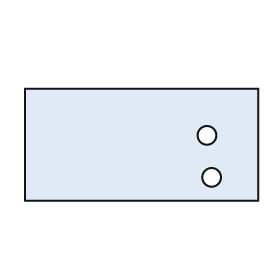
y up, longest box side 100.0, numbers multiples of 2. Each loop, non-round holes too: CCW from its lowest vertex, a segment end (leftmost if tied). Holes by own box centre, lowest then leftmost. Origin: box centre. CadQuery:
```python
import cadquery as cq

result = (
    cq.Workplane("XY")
    .moveTo(-50.0, -24.0)
    .lineTo(50.0, -24.0)
    .lineTo(50.0, 24.0)
    .lineTo(-50.0, 24.0)
    .close()
    .moveTo(30.0, -14.0)
    .circle(4.0)
    .moveTo(28.0, 4.0)
    .circle(4.0)
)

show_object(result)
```